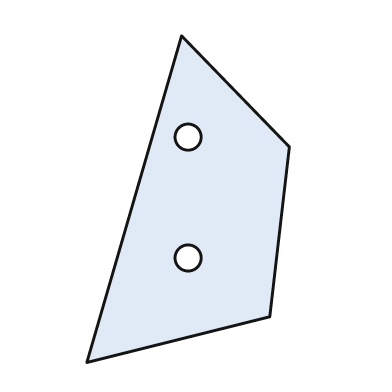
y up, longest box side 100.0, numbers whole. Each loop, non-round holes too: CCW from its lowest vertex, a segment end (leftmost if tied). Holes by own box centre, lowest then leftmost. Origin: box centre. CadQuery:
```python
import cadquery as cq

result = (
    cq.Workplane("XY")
    .moveTo(-31.0, -50.0)
    .lineTo(25.0, -36.0)
    .lineTo(31.0, 16.0)
    .lineTo(-2.0, 50.0)
    .close()
    .moveTo(0.0, -18.0)
    .circle(4.0)
    .moveTo(0.0, 19.0)
    .circle(4.0)
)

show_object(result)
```